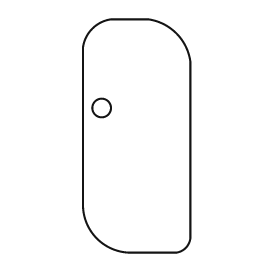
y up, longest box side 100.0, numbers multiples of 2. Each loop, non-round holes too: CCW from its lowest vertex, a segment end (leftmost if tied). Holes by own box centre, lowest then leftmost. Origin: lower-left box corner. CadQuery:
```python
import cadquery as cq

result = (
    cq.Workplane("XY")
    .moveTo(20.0, 0.0)
    .lineTo(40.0, 0.0)
    .threePointArc((44.0, 2.0), (46.0, 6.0))
    .lineTo(46.0, 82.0)
    .threePointArc((40.0, 94.0), (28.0, 100.0))
    .lineTo(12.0, 100.0)
    .threePointArc((4.0, 96.0), (0.0, 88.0))
    .lineTo(0.0, 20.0)
    .threePointArc((6.0, 6.0), (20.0, 0.0))
    .close()
    .moveTo(8.0, 62.0)
    .circle(4.0)
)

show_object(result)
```